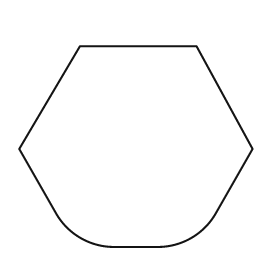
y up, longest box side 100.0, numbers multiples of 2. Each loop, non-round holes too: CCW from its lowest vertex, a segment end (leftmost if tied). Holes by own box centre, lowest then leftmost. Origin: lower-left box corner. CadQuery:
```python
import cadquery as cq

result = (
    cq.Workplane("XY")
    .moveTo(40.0, 0.0)
    .lineTo(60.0, 0.0)
    .threePointArc((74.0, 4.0), (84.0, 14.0))
    .lineTo(100.0, 42.0)
    .lineTo(76.0, 86.0)
    .lineTo(26.0, 86.0)
    .lineTo(0.0, 42.0)
    .lineTo(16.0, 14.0)
    .threePointArc((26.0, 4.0), (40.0, 0.0))
    .close()
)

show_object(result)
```